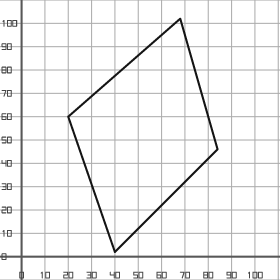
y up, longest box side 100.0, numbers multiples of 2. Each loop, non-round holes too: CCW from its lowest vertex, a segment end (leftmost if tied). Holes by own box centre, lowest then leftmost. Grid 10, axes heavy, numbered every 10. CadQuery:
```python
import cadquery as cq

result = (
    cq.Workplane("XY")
    .moveTo(40.0, 2.0)
    .lineTo(84.0, 46.0)
    .lineTo(68.0, 102.0)
    .lineTo(20.0, 60.0)
    .close()
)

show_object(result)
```